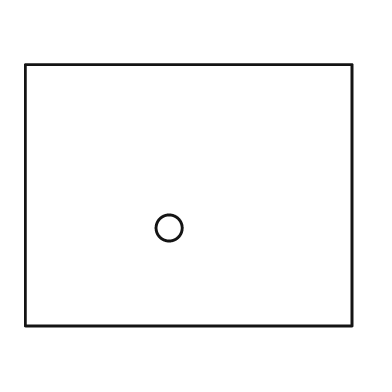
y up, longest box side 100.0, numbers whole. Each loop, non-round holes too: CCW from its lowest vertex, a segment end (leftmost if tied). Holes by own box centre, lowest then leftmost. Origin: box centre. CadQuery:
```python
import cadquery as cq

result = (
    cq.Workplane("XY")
    .moveTo(-50.0, -40.0)
    .lineTo(50.0, -40.0)
    .lineTo(50.0, 40.0)
    .lineTo(-50.0, 40.0)
    .close()
    .moveTo(-6.0, -10.0)
    .circle(4.0)
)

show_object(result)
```